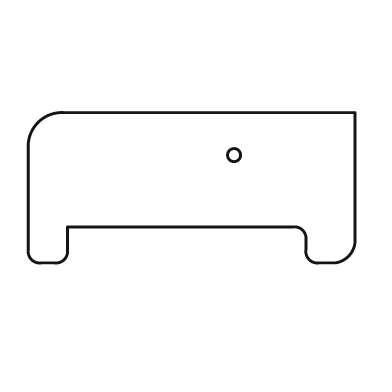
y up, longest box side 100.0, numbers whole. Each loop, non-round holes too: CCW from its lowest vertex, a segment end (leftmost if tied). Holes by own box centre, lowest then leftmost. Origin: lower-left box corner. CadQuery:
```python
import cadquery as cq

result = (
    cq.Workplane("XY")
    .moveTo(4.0, 0.0)
    .lineTo(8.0, 0.0)
    .threePointArc((11.0, 1.0), (12.0, 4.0))
    .lineTo(12.0, 11.0)
    .lineTo(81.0, 11.0)
    .threePointArc((84.0, 10.0), (85.0, 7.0))
    .lineTo(85.0, 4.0)
    .threePointArc((86.0, 1.0), (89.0, 0.0))
    .lineTo(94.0, 0.0)
    .threePointArc((98.0, 2.0), (100.0, 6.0))
    .lineTo(100.0, 46.0)
    .lineTo(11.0, 46.0)
    .threePointArc((3.0, 43.0), (0.0, 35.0))
    .lineTo(0.0, 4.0)
    .threePointArc((1.0, 1.0), (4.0, 0.0))
    .close()
    .moveTo(63.0, 33.0)
    .circle(2.0)
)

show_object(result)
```